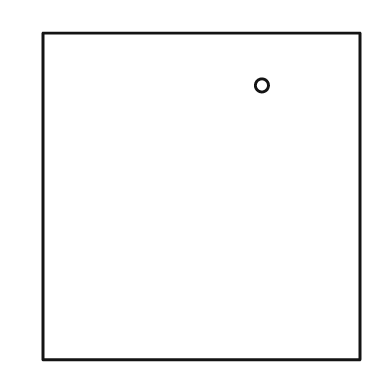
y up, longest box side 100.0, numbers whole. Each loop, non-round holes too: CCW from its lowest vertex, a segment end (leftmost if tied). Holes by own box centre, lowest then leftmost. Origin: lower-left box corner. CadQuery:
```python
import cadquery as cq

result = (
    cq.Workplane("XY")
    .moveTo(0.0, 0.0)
    .lineTo(97.0, 0.0)
    .lineTo(97.0, 100.0)
    .lineTo(0.0, 100.0)
    .close()
    .moveTo(67.0, 84.0)
    .circle(2.0)
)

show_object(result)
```